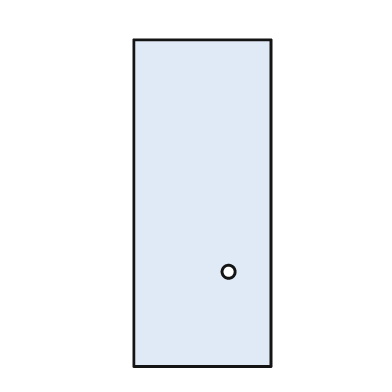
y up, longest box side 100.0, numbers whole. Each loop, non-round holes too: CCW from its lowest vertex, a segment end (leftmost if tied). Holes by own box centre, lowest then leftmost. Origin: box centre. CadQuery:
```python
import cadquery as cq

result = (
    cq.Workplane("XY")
    .moveTo(-21.0, -50.0)
    .lineTo(21.0, -50.0)
    .lineTo(21.0, 50.0)
    .lineTo(-21.0, 50.0)
    .close()
    .moveTo(8.0, -21.0)
    .circle(2.0)
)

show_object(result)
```